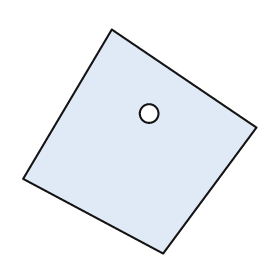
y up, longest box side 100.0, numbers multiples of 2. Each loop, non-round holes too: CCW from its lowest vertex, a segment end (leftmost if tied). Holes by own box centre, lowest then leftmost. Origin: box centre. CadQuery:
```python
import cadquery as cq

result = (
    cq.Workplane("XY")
    .moveTo(10.0, -48.0)
    .lineTo(50.0, 6.0)
    .lineTo(-12.0, 48.0)
    .lineTo(-50.0, -16.0)
    .close()
    .moveTo(4.0, 12.0)
    .circle(4.0)
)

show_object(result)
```